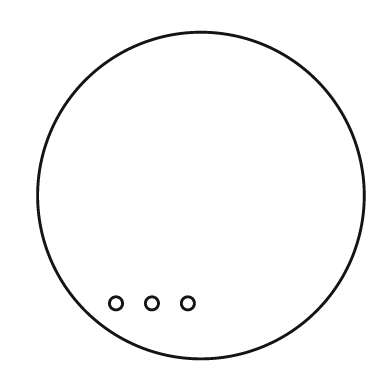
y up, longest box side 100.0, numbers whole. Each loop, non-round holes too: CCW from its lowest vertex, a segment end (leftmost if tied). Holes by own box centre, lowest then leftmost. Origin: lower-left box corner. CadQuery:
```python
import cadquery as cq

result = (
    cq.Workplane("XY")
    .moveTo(50.0, 50.0)
    .circle(50.0)
    .moveTo(24.0, 17.0)
    .circle(2.0)
    .moveTo(35.0, 17.0)
    .circle(2.0)
    .moveTo(46.0, 17.0)
    .circle(2.0)
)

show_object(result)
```